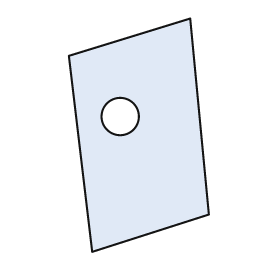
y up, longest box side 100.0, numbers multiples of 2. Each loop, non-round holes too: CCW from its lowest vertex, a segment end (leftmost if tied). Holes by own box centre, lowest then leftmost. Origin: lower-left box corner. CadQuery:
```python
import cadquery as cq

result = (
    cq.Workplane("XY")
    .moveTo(10.0, 0.0)
    .lineTo(60.0, 16.0)
    .lineTo(52.0, 100.0)
    .lineTo(0.0, 84.0)
    .close()
    .moveTo(22.0, 58.0)
    .circle(8.0)
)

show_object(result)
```